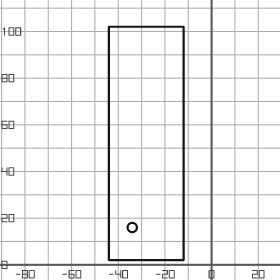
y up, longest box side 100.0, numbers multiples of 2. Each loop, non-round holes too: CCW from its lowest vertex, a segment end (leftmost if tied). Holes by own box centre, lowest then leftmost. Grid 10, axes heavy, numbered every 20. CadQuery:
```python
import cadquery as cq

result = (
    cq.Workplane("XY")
    .moveTo(-44.0, 2.0)
    .lineTo(-12.0, 2.0)
    .lineTo(-12.0, 102.0)
    .lineTo(-44.0, 102.0)
    .close()
    .moveTo(-34.0, 16.0)
    .circle(2.0)
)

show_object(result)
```